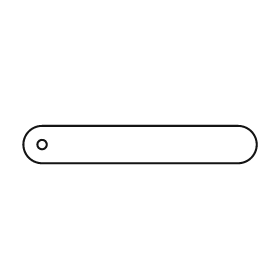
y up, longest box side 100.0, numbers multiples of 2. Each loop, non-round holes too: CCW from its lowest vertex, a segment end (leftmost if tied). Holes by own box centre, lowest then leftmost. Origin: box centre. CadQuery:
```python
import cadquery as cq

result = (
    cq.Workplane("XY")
    .moveTo(-42.0, -8.0)
    .lineTo(42.0, -8.0)
    .threePointArc((50.0, 0.0), (42.0, 8.0))
    .lineTo(-42.0, 8.0)
    .threePointArc((-50.0, 0.0), (-42.0, -8.0))
    .close()
    .moveTo(-42.0, 0.0)
    .circle(2.0)
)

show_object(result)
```